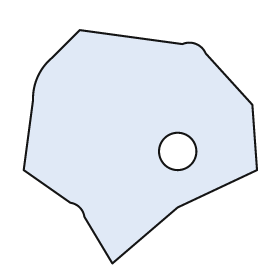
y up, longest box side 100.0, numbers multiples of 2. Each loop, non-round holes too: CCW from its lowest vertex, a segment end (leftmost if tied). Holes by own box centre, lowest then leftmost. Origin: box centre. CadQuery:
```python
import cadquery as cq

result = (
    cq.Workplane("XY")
    .moveTo(-12.0, -50.0)
    .lineTo(16.0, -26.0)
    .lineTo(50.0, -10.0)
    .lineTo(48.0, 18.0)
    .lineTo(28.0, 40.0)
    .threePointArc((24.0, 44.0), (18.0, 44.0))
    .lineTo(-26.0, 50.0)
    .lineTo(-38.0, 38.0)
    .threePointArc((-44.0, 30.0), (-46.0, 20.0))
    .lineTo(-50.0, -10.0)
    .lineTo(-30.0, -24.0)
    .threePointArc((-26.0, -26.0), (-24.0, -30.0))
    .close()
    .moveTo(16.0, -2.0)
    .circle(8.0)
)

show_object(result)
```